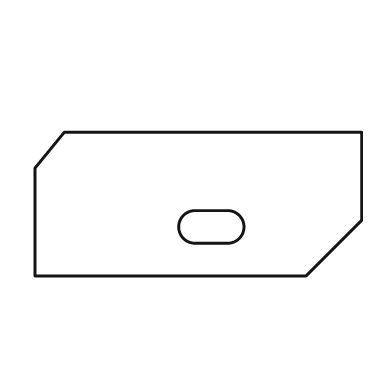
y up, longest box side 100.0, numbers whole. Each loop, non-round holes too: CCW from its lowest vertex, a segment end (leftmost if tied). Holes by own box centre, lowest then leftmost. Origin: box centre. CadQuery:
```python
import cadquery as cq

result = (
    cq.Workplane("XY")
    .moveTo(-50.0, -22.0)
    .lineTo(33.0, -22.0)
    .lineTo(50.0, -5.0)
    .lineTo(50.0, 22.0)
    .lineTo(-41.0, 22.0)
    .lineTo(-50.0, 11.0)
    .close()
    .moveTo(-1.0, -12.0)
    .lineTo(9.0, -12.0)
    .threePointArc((14.0, -7.0), (9.0, -2.0))
    .lineTo(-1.0, -2.0)
    .threePointArc((-6.0, -7.0), (-1.0, -12.0))
    .close()
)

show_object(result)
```